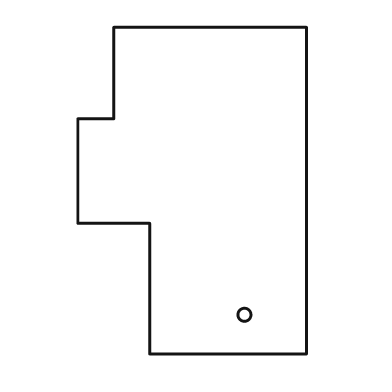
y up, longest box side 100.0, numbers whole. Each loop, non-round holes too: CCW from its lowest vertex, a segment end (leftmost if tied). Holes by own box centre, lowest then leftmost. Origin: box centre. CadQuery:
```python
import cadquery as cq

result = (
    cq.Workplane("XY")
    .moveTo(-13.0, -50.0)
    .lineTo(35.0, -50.0)
    .lineTo(35.0, 50.0)
    .lineTo(-24.0, 50.0)
    .lineTo(-24.0, 22.0)
    .lineTo(-35.0, 22.0)
    .lineTo(-35.0, -10.0)
    .lineTo(-13.0, -10.0)
    .close()
    .moveTo(16.0, -38.0)
    .circle(2.0)
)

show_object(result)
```